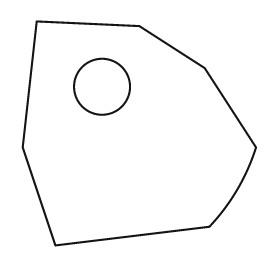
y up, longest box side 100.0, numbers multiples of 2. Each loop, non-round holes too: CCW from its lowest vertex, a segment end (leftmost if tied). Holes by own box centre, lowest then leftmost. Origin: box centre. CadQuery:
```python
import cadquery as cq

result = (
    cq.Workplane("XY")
    .moveTo(-36.0, -48.0)
    .lineTo(30.0, -40.0)
    .threePointArc((42.0, -24.0), (50.0, -6.0))
    .lineTo(28.0, 28.0)
    .lineTo(0.0, 46.0)
    .lineTo(-44.0, 48.0)
    .lineTo(-50.0, -6.0)
    .close()
    .moveTo(-16.0, 20.0)
    .circle(12.0)
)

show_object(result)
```